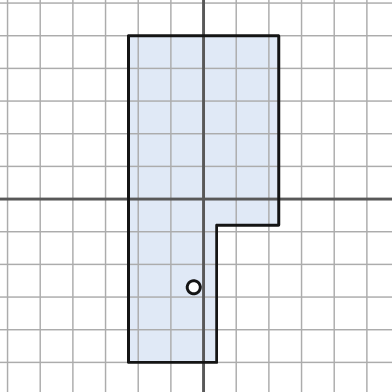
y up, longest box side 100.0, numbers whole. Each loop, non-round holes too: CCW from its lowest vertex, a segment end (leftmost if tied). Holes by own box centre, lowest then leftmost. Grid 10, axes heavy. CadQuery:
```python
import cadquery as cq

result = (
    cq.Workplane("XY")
    .moveTo(-23.0, -50.0)
    .lineTo(4.0, -50.0)
    .lineTo(4.0, -8.0)
    .lineTo(23.0, -8.0)
    .lineTo(23.0, 50.0)
    .lineTo(-23.0, 50.0)
    .close()
    .moveTo(-3.0, -27.0)
    .circle(2.0)
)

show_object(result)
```